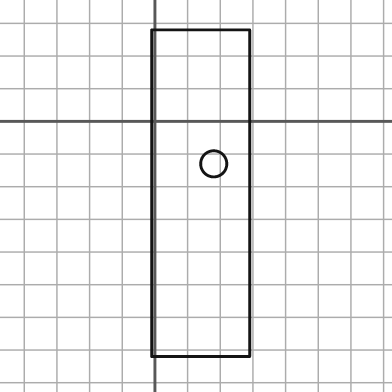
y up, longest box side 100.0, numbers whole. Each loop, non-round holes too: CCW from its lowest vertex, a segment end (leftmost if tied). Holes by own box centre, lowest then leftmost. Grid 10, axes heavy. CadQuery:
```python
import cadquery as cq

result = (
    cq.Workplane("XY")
    .moveTo(-1.0, -72.0)
    .lineTo(29.0, -72.0)
    .lineTo(29.0, 28.0)
    .lineTo(-1.0, 28.0)
    .close()
    .moveTo(18.0, -13.0)
    .circle(4.0)
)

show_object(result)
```